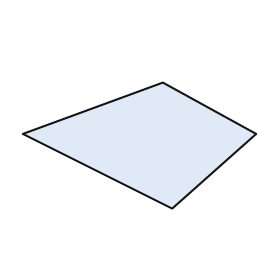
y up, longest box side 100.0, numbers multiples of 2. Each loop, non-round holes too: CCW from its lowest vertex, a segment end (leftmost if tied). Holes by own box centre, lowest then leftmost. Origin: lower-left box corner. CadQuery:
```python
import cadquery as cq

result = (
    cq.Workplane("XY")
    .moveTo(64.0, 0.0)
    .lineTo(100.0, 32.0)
    .lineTo(60.0, 54.0)
    .lineTo(0.0, 32.0)
    .close()
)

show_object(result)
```